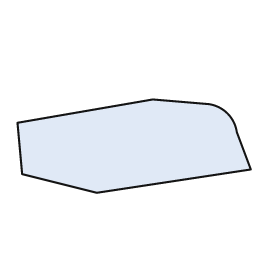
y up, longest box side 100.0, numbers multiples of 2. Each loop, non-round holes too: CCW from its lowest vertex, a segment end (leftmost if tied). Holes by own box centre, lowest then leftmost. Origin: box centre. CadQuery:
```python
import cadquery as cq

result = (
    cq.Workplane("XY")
    .moveTo(-16.0, -20.0)
    .lineTo(50.0, -10.0)
    .lineTo(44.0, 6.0)
    .threePointArc((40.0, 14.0), (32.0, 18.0))
    .lineTo(8.0, 20.0)
    .lineTo(-50.0, 10.0)
    .lineTo(-48.0, -12.0)
    .close()
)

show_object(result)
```